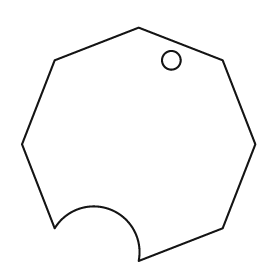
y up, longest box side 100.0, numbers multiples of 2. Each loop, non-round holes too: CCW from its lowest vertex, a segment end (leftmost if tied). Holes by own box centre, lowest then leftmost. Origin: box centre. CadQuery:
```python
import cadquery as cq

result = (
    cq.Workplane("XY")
    .moveTo(0.0, -50.0)
    .lineTo(36.0, -36.0)
    .lineTo(50.0, 0.0)
    .lineTo(36.0, 36.0)
    .lineTo(0.0, 50.0)
    .lineTo(-36.0, 36.0)
    .lineTo(-50.0, 0.0)
    .lineTo(-36.0, -36.0)
    .threePointArc((-12.0, -28.0), (0.0, -50.0))
    .close()
    .moveTo(14.0, 36.0)
    .circle(4.0)
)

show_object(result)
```